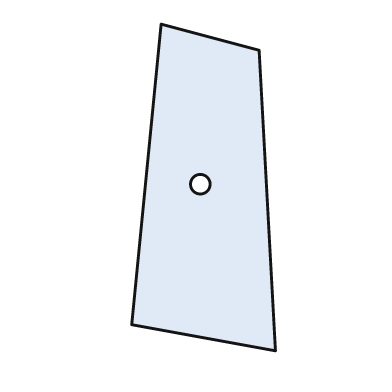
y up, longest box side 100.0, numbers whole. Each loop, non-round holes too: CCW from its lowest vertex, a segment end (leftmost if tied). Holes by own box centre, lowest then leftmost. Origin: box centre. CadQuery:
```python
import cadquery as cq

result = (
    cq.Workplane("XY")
    .moveTo(22.0, -50.0)
    .lineTo(17.0, 42.0)
    .lineTo(-13.0, 50.0)
    .lineTo(-22.0, -42.0)
    .close()
    .moveTo(-1.0, 1.0)
    .circle(3.0)
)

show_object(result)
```